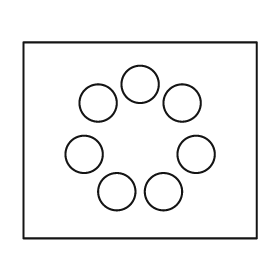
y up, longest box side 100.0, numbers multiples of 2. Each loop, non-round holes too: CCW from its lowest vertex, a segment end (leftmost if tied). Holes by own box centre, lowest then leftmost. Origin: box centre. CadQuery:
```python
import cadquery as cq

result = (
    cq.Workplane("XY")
    .moveTo(-50.0, -42.0)
    .lineTo(50.0, -42.0)
    .lineTo(50.0, 42.0)
    .lineTo(-50.0, 42.0)
    .close()
    .moveTo(-10.0, -22.0)
    .circle(8.0)
    .moveTo(10.0, -22.0)
    .circle(8.0)
    .moveTo(-24.0, -6.0)
    .circle(8.0)
    .moveTo(24.0, -6.0)
    .circle(8.0)
    .moveTo(-18.0, 16.0)
    .circle(8.0)
    .moveTo(18.0, 16.0)
    .circle(8.0)
    .moveTo(0.0, 24.0)
    .circle(8.0)
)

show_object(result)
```